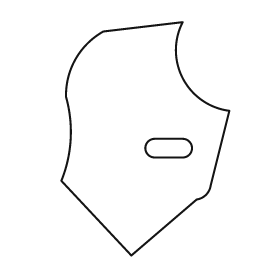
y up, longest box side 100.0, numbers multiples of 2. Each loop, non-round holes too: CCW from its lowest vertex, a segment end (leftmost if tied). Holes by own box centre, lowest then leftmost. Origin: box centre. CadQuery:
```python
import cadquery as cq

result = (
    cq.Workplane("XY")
    .moveTo(-6.0, -50.0)
    .lineTo(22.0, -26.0)
    .threePointArc((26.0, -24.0), (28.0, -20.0))
    .lineTo(36.0, 12.0)
    .threePointArc((16.0, 26.0), (16.0, 50.0))
    .lineTo(-18.0, 46.0)
    .threePointArc((-30.0, 34.0), (-34.0, 18.0))
    .threePointArc((-32.0, 0.0), (-36.0, -18.0))
    .close()
    .moveTo(4.0, -8.0)
    .lineTo(16.0, -8.0)
    .threePointArc((20.0, -4.0), (16.0, 0.0))
    .lineTo(4.0, 0.0)
    .threePointArc((0.0, -4.0), (4.0, -8.0))
    .close()
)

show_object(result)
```